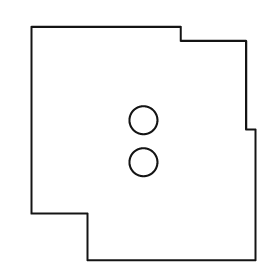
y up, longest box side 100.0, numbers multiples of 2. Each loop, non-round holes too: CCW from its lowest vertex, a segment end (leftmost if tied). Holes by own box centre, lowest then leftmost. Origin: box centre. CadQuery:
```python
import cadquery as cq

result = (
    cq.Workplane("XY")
    .moveTo(-24.0, -50.0)
    .lineTo(48.0, -50.0)
    .lineTo(48.0, 6.0)
    .lineTo(44.0, 6.0)
    .lineTo(44.0, 44.0)
    .lineTo(16.0, 44.0)
    .lineTo(16.0, 50.0)
    .lineTo(-48.0, 50.0)
    .lineTo(-48.0, -30.0)
    .lineTo(-24.0, -30.0)
    .close()
    .moveTo(0.0, -8.0)
    .circle(6.0)
    .moveTo(0.0, 10.0)
    .circle(6.0)
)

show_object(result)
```